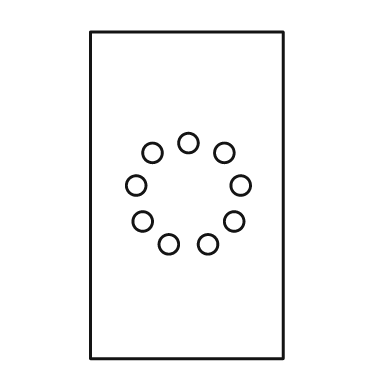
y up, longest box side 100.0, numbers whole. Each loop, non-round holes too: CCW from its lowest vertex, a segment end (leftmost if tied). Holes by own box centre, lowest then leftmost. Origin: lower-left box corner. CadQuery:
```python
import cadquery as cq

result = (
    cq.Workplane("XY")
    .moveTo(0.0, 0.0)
    .lineTo(59.0, 0.0)
    .lineTo(59.0, 100.0)
    .lineTo(0.0, 100.0)
    .close()
    .moveTo(24.0, 35.0)
    .circle(3.0)
    .moveTo(36.0, 35.0)
    .circle(3.0)
    .moveTo(16.0, 42.0)
    .circle(3.0)
    .moveTo(44.0, 42.0)
    .circle(3.0)
    .moveTo(14.0, 53.0)
    .circle(3.0)
    .moveTo(46.0, 53.0)
    .circle(3.0)
    .moveTo(19.0, 63.0)
    .circle(3.0)
    .moveTo(41.0, 63.0)
    .circle(3.0)
    .moveTo(30.0, 66.0)
    .circle(3.0)
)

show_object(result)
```